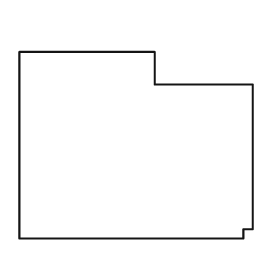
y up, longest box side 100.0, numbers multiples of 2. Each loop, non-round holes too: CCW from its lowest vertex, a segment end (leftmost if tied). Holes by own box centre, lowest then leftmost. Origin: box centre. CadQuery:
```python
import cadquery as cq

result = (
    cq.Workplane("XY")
    .moveTo(-50.0, -40.0)
    .lineTo(46.0, -40.0)
    .lineTo(46.0, -36.0)
    .lineTo(50.0, -36.0)
    .lineTo(50.0, 26.0)
    .lineTo(8.0, 26.0)
    .lineTo(8.0, 40.0)
    .lineTo(-50.0, 40.0)
    .close()
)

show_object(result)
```